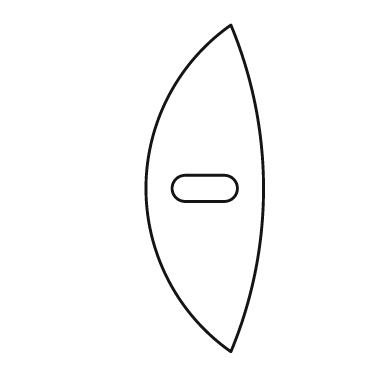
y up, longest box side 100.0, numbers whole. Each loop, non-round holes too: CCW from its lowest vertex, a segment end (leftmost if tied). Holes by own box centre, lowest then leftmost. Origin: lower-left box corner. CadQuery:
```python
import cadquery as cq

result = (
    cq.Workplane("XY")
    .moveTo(26.0, 0.0)
    .threePointArc((36.0, 50.0), (26.0, 100.0))
    .threePointArc((0.0, 50.0), (26.0, 0.0))
    .close()
    .moveTo(12.0, 46.0)
    .lineTo(24.0, 46.0)
    .threePointArc((28.0, 50.0), (24.0, 54.0))
    .lineTo(12.0, 54.0)
    .threePointArc((8.0, 50.0), (12.0, 46.0))
    .close()
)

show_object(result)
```